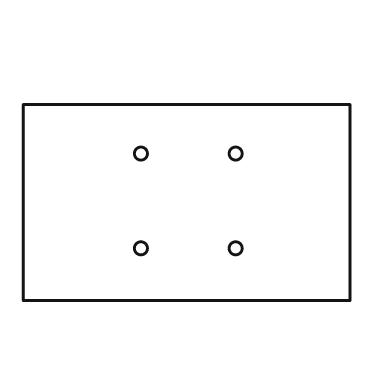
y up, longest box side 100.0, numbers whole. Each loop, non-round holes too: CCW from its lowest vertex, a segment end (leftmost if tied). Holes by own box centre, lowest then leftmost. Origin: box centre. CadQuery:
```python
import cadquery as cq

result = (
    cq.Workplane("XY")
    .moveTo(-50.0, -30.0)
    .lineTo(50.0, -30.0)
    .lineTo(50.0, 30.0)
    .lineTo(-50.0, 30.0)
    .close()
    .moveTo(-14.0, -14.0)
    .circle(2.0)
    .moveTo(15.0, -14.0)
    .circle(2.0)
    .moveTo(-14.0, 15.0)
    .circle(2.0)
    .moveTo(15.0, 15.0)
    .circle(2.0)
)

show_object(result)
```